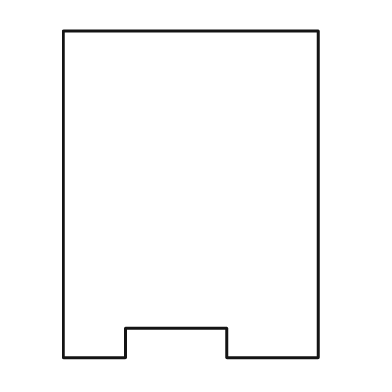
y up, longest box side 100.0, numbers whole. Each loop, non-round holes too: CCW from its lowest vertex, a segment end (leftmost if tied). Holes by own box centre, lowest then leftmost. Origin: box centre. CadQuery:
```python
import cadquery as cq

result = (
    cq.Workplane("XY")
    .moveTo(-39.0, -50.0)
    .lineTo(-20.0, -50.0)
    .lineTo(-20.0, -41.0)
    .lineTo(11.0, -41.0)
    .lineTo(11.0, -50.0)
    .lineTo(39.0, -50.0)
    .lineTo(39.0, 50.0)
    .lineTo(-39.0, 50.0)
    .close()
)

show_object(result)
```